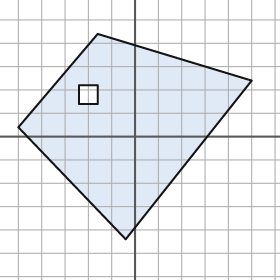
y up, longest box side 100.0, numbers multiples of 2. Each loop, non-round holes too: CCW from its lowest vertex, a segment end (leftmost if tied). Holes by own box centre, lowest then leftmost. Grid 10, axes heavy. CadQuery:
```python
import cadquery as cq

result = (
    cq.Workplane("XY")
    .moveTo(-4.0, -44.0)
    .lineTo(50.0, 24.0)
    .lineTo(-16.0, 44.0)
    .lineTo(-50.0, 4.0)
    .close()
    .moveTo(-24.0, 14.0)
    .lineTo(-16.0, 14.0)
    .lineTo(-16.0, 22.0)
    .lineTo(-24.0, 22.0)
    .close()
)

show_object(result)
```